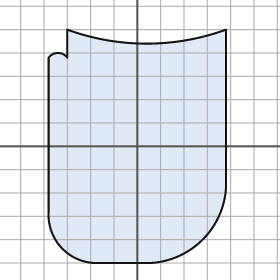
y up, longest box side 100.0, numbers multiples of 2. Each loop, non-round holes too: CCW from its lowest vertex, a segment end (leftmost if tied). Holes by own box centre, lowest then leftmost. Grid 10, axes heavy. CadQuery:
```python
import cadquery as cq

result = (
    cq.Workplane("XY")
    .moveTo(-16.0, -50.0)
    .lineTo(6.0, -50.0)
    .threePointArc((28.0, -40.0), (38.0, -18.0))
    .lineTo(38.0, 50.0)
    .threePointArc((4.0, 44.0), (-30.0, 50.0))
    .lineTo(-30.0, 38.0)
    .threePointArc((-34.0, 40.0), (-38.0, 38.0))
    .lineTo(-38.0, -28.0)
    .threePointArc((-32.0, -44.0), (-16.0, -50.0))
    .close()
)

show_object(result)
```